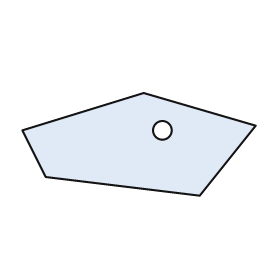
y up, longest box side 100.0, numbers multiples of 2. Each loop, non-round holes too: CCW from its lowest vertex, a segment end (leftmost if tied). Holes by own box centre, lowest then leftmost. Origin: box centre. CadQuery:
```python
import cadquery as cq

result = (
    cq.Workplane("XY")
    .moveTo(26.0, -22.0)
    .lineTo(50.0, 8.0)
    .lineTo(2.0, 22.0)
    .lineTo(-50.0, 6.0)
    .lineTo(-40.0, -14.0)
    .close()
    .moveTo(10.0, 6.0)
    .circle(4.0)
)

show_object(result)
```